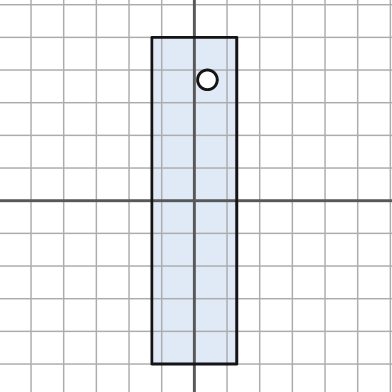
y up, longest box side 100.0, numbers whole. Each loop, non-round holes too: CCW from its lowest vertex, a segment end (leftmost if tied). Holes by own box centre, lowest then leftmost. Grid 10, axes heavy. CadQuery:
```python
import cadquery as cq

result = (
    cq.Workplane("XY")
    .moveTo(-13.0, -50.0)
    .lineTo(13.0, -50.0)
    .lineTo(13.0, 50.0)
    .lineTo(-13.0, 50.0)
    .close()
    .moveTo(4.0, 37.0)
    .circle(3.0)
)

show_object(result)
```